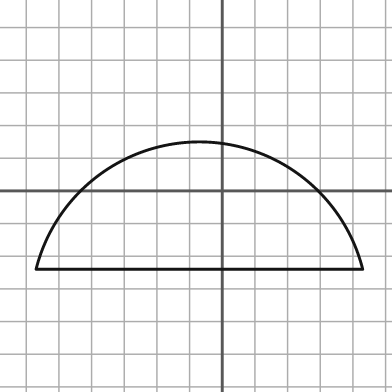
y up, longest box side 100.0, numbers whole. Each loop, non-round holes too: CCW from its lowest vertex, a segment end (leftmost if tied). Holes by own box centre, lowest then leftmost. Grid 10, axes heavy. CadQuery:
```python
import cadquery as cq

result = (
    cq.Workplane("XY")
    .moveTo(-57.0, -24.0)
    .lineTo(43.0, -24.0)
    .threePointArc((-7.0, 15.0), (-57.0, -24.0))
    .close()
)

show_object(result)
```